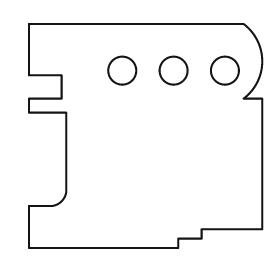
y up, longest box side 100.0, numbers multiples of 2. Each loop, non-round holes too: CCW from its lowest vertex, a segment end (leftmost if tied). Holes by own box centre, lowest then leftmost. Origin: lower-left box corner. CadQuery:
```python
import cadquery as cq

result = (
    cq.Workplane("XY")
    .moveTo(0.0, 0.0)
    .lineTo(64.0, 0.0)
    .lineTo(64.0, 4.0)
    .lineTo(74.0, 4.0)
    .lineTo(74.0, 8.0)
    .lineTo(100.0, 8.0)
    .lineTo(100.0, 64.0)
    .lineTo(92.0, 64.0)
    .threePointArc((100.0, 80.0), (92.0, 96.0))
    .lineTo(0.0, 96.0)
    .lineTo(0.0, 74.0)
    .lineTo(14.0, 74.0)
    .lineTo(14.0, 64.0)
    .lineTo(0.0, 64.0)
    .lineTo(0.0, 58.0)
    .lineTo(16.0, 58.0)
    .lineTo(16.0, 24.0)
    .threePointArc((14.0, 20.0), (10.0, 18.0))
    .lineTo(0.0, 18.0)
    .close()
    .moveTo(40.0, 76.0)
    .circle(6.0)
    .moveTo(62.0, 76.0)
    .circle(6.0)
    .moveTo(84.0, 76.0)
    .circle(6.0)
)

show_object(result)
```